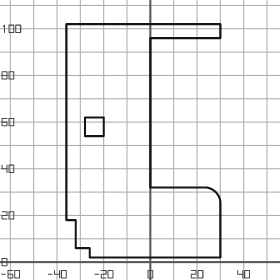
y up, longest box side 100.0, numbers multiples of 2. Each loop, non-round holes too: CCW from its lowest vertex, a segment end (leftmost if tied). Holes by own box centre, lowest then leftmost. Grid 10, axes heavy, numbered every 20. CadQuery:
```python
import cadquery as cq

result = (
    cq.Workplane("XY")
    .moveTo(-26.0, 2.0)
    .lineTo(30.0, 2.0)
    .lineTo(30.0, 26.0)
    .threePointArc((28.0, 30.0), (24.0, 32.0))
    .lineTo(0.0, 32.0)
    .lineTo(0.0, 96.0)
    .lineTo(30.0, 96.0)
    .lineTo(30.0, 102.0)
    .lineTo(-36.0, 102.0)
    .lineTo(-36.0, 18.0)
    .lineTo(-32.0, 18.0)
    .lineTo(-32.0, 6.0)
    .lineTo(-26.0, 6.0)
    .close()
    .moveTo(-28.0, 54.0)
    .lineTo(-20.0, 54.0)
    .lineTo(-20.0, 62.0)
    .lineTo(-28.0, 62.0)
    .close()
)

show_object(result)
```